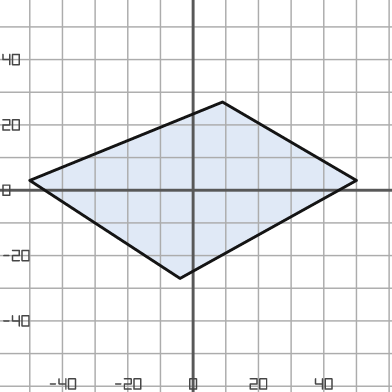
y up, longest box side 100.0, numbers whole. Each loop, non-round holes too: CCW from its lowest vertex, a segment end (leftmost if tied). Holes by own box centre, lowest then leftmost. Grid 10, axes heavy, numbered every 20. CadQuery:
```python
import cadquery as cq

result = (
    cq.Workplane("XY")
    .moveTo(-4.0, -27.0)
    .lineTo(50.0, 3.0)
    .lineTo(9.0, 27.0)
    .lineTo(-50.0, 3.0)
    .close()
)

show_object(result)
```